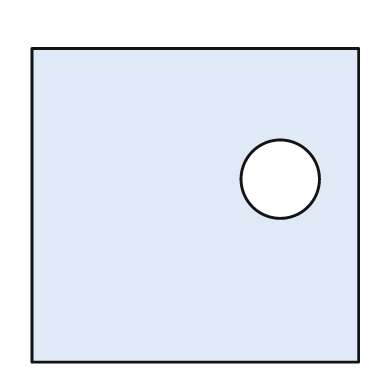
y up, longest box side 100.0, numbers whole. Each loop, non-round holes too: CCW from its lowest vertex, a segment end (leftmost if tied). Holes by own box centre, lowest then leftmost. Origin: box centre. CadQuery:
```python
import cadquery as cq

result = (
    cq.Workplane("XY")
    .moveTo(-50.0, -48.0)
    .lineTo(50.0, -48.0)
    .lineTo(50.0, 48.0)
    .lineTo(-50.0, 48.0)
    .close()
    .moveTo(26.0, 8.0)
    .circle(12.0)
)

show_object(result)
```